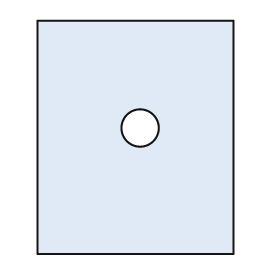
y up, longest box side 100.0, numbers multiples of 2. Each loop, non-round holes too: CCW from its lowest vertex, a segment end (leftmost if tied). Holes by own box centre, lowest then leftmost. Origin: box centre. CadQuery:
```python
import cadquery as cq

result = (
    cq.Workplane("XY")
    .moveTo(-42.0, -50.0)
    .lineTo(42.0, -50.0)
    .lineTo(42.0, 50.0)
    .lineTo(-42.0, 50.0)
    .close()
    .moveTo(2.0, 4.0)
    .circle(8.0)
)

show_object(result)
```